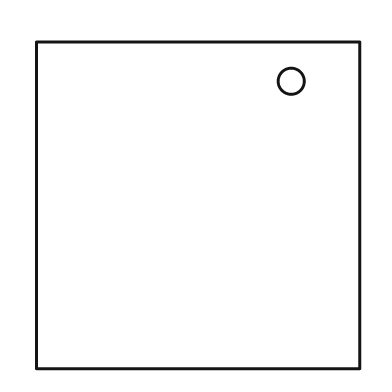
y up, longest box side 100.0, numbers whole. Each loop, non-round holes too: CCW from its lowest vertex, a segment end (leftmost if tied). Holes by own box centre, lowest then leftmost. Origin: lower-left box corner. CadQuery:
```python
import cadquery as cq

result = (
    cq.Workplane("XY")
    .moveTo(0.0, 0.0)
    .lineTo(99.0, 0.0)
    .lineTo(99.0, 100.0)
    .lineTo(0.0, 100.0)
    .close()
    .moveTo(78.0, 88.0)
    .circle(4.0)
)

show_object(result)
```